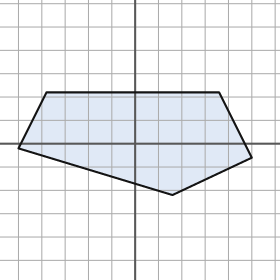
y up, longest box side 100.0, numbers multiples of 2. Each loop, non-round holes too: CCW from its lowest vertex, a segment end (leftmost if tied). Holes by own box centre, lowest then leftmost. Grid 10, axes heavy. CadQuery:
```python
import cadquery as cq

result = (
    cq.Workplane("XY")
    .moveTo(16.0, -22.0)
    .lineTo(50.0, -6.0)
    .lineTo(36.0, 22.0)
    .lineTo(-38.0, 22.0)
    .lineTo(-50.0, -2.0)
    .close()
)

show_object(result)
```